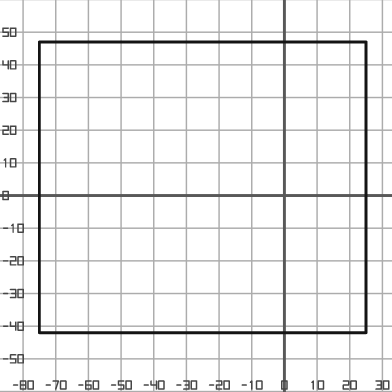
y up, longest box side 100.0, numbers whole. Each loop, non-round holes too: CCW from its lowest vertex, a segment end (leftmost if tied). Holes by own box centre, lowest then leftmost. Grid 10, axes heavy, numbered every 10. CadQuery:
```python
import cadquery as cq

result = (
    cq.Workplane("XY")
    .moveTo(-75.0, -42.0)
    .lineTo(25.0, -42.0)
    .lineTo(25.0, 47.0)
    .lineTo(-75.0, 47.0)
    .close()
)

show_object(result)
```